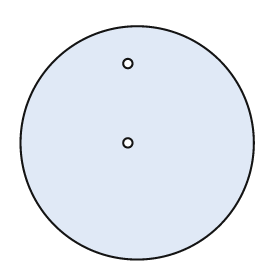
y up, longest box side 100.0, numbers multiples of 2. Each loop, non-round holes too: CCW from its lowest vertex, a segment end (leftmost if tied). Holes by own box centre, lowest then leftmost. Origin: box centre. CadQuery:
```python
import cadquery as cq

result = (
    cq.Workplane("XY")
    .moveTo(0.0, 0.0)
    .circle(50.0)
    .moveTo(-4.0, 0.0)
    .circle(2.0)
    .moveTo(-4.0, 34.0)
    .circle(2.0)
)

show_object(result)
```